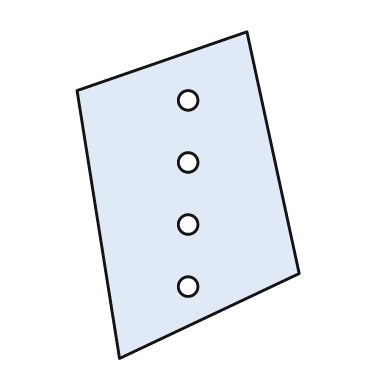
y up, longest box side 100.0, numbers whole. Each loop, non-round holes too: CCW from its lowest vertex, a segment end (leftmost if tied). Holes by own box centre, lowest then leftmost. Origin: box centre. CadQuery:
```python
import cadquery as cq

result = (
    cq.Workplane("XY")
    .moveTo(-21.0, -50.0)
    .lineTo(34.0, -24.0)
    .lineTo(18.0, 50.0)
    .lineTo(-34.0, 32.0)
    .close()
    .moveTo(0.0, -28.0)
    .circle(3.0)
    .moveTo(0.0, -9.0)
    .circle(3.0)
    .moveTo(0.0, 10.0)
    .circle(3.0)
    .moveTo(0.0, 29.0)
    .circle(3.0)
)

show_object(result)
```